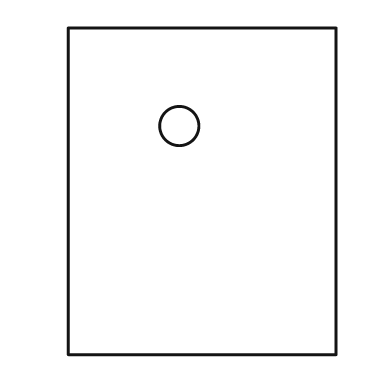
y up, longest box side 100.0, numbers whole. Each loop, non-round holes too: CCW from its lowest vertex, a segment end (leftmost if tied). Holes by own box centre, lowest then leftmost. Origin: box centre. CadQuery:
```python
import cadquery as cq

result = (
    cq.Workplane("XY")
    .moveTo(-41.0, -50.0)
    .lineTo(41.0, -50.0)
    .lineTo(41.0, 50.0)
    .lineTo(-41.0, 50.0)
    .close()
    .moveTo(-7.0, 20.0)
    .circle(6.0)
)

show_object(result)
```